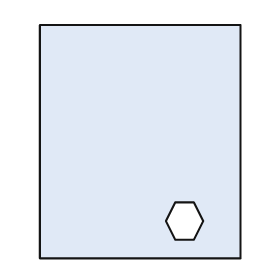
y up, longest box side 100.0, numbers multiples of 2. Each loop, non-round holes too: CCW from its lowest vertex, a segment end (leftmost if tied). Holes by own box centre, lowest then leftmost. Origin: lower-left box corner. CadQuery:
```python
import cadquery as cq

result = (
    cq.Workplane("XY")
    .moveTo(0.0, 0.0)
    .lineTo(86.0, 0.0)
    .lineTo(86.0, 100.0)
    .lineTo(0.0, 100.0)
    .close()
    .moveTo(58.0, 8.0)
    .lineTo(66.0, 8.0)
    .lineTo(70.0, 16.0)
    .lineTo(66.0, 24.0)
    .lineTo(58.0, 24.0)
    .lineTo(54.0, 16.0)
    .close()
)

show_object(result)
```